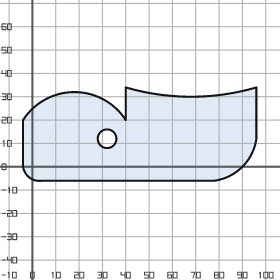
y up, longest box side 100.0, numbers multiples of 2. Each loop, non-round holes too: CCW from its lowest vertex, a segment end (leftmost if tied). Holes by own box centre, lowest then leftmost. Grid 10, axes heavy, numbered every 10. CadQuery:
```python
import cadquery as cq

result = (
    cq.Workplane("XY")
    .moveTo(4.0, -6.0)
    .lineTo(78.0, -6.0)
    .threePointArc((90.0, 0.0), (96.0, 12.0))
    .lineTo(96.0, 34.0)
    .threePointArc((68.0, 30.0), (40.0, 34.0))
    .lineTo(40.0, 20.0)
    .threePointArc((18.0, 32.0), (-4.0, 20.0))
    .lineTo(-4.0, 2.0)
    .threePointArc((-2.0, -4.0), (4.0, -6.0))
    .close()
    .moveTo(32.0, 12.0)
    .circle(4.0)
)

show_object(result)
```